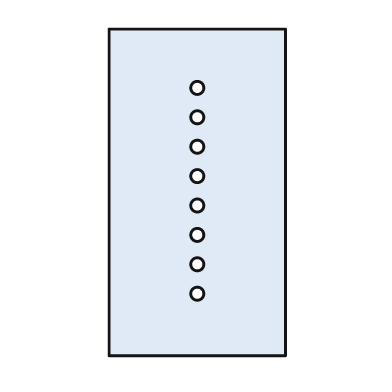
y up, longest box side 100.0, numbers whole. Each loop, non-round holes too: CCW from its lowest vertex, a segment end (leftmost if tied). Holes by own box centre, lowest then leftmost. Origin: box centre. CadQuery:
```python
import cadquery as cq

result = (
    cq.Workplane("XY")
    .moveTo(-27.0, -50.0)
    .lineTo(27.0, -50.0)
    .lineTo(27.0, 50.0)
    .lineTo(-27.0, 50.0)
    .close()
    .moveTo(0.0, -31.0)
    .circle(2.0)
    .moveTo(0.0, -22.0)
    .circle(2.0)
    .moveTo(0.0, -13.0)
    .circle(2.0)
    .moveTo(0.0, -4.0)
    .circle(2.0)
    .moveTo(0.0, 5.0)
    .circle(2.0)
    .moveTo(0.0, 14.0)
    .circle(2.0)
    .moveTo(0.0, 23.0)
    .circle(2.0)
    .moveTo(0.0, 32.0)
    .circle(2.0)
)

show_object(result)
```